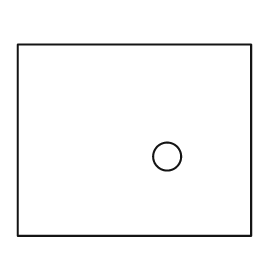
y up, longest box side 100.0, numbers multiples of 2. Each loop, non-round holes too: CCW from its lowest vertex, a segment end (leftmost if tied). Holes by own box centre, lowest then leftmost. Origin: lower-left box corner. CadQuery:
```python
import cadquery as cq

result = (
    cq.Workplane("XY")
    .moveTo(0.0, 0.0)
    .lineTo(100.0, 0.0)
    .lineTo(100.0, 82.0)
    .lineTo(0.0, 82.0)
    .close()
    .moveTo(64.0, 34.0)
    .circle(6.0)
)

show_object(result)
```